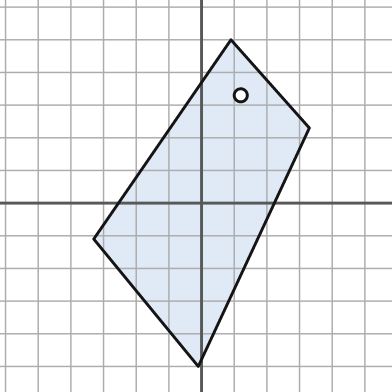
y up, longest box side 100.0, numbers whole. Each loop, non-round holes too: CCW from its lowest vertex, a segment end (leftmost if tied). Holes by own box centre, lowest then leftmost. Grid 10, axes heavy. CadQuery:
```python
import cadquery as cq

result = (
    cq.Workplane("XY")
    .moveTo(-1.0, -50.0)
    .lineTo(33.0, 23.0)
    .lineTo(9.0, 50.0)
    .lineTo(-33.0, -11.0)
    .close()
    .moveTo(12.0, 33.0)
    .circle(2.0)
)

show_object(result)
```